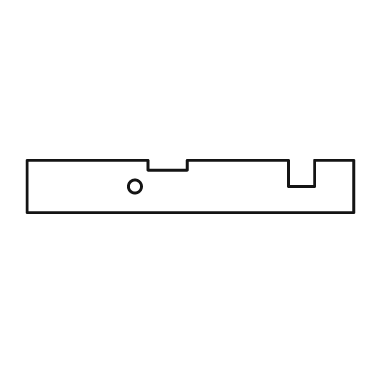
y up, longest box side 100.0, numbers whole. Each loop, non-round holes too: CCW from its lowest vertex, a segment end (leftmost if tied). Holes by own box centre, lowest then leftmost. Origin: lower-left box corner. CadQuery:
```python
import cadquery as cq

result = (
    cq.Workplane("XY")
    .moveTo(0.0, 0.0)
    .lineTo(100.0, 0.0)
    .lineTo(100.0, 16.0)
    .lineTo(88.0, 16.0)
    .lineTo(88.0, 8.0)
    .lineTo(80.0, 8.0)
    .lineTo(80.0, 16.0)
    .lineTo(49.0, 16.0)
    .lineTo(49.0, 13.0)
    .lineTo(37.0, 13.0)
    .lineTo(37.0, 16.0)
    .lineTo(0.0, 16.0)
    .close()
    .moveTo(33.0, 8.0)
    .circle(2.0)
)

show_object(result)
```